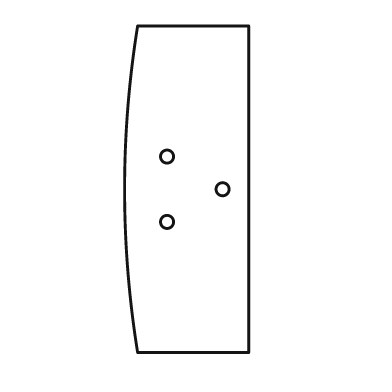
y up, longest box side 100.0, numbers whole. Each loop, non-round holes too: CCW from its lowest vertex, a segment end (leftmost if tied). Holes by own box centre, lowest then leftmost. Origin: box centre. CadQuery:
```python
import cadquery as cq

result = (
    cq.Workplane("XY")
    .moveTo(-15.0, -50.0)
    .lineTo(19.0, -50.0)
    .lineTo(19.0, 50.0)
    .lineTo(-15.0, 50.0)
    .threePointArc((-19.0, 0.0), (-15.0, -50.0))
    .close()
    .moveTo(-6.0, -10.0)
    .circle(2.0)
    .moveTo(11.0, 0.0)
    .circle(2.0)
    .moveTo(-6.0, 10.0)
    .circle(2.0)
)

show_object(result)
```